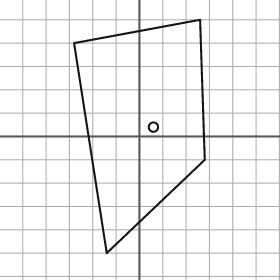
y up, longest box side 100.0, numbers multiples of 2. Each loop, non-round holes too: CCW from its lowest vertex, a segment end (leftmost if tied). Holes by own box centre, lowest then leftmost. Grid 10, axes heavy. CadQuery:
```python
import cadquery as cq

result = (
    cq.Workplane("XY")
    .moveTo(-14.0, -50.0)
    .lineTo(28.0, -10.0)
    .lineTo(26.0, 50.0)
    .lineTo(-28.0, 40.0)
    .close()
    .moveTo(6.0, 4.0)
    .circle(2.0)
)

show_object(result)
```